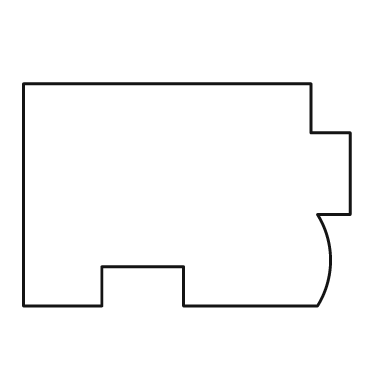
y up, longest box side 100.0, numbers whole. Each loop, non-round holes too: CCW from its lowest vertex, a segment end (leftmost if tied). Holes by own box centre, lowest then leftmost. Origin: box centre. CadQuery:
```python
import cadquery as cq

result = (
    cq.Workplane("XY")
    .moveTo(-50.0, -34.0)
    .lineTo(-26.0, -34.0)
    .lineTo(-26.0, -22.0)
    .lineTo(-1.0, -22.0)
    .lineTo(-1.0, -34.0)
    .lineTo(40.0, -34.0)
    .threePointArc((44.0, -20.0), (40.0, -6.0))
    .lineTo(50.0, -6.0)
    .lineTo(50.0, 19.0)
    .lineTo(38.0, 19.0)
    .lineTo(38.0, 34.0)
    .lineTo(-50.0, 34.0)
    .close()
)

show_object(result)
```